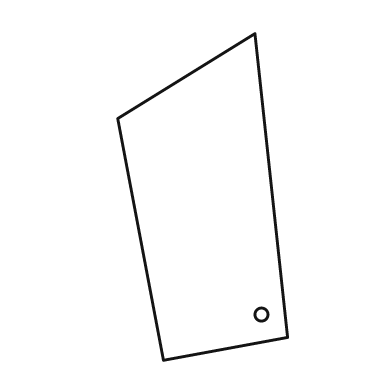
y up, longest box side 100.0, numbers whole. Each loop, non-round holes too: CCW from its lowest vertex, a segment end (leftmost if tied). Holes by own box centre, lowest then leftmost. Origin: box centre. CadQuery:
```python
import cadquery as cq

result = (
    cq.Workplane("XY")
    .moveTo(-12.0, -50.0)
    .lineTo(26.0, -43.0)
    .lineTo(16.0, 50.0)
    .lineTo(-26.0, 24.0)
    .close()
    .moveTo(18.0, -36.0)
    .circle(2.0)
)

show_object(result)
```